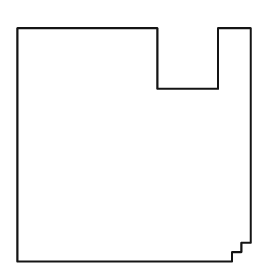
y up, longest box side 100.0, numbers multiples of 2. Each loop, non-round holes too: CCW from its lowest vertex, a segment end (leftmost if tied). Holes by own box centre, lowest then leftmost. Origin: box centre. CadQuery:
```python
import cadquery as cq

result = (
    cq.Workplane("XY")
    .moveTo(-50.0, -50.0)
    .lineTo(42.0, -50.0)
    .lineTo(42.0, -46.0)
    .lineTo(46.0, -46.0)
    .lineTo(46.0, -42.0)
    .lineTo(50.0, -42.0)
    .lineTo(50.0, 50.0)
    .lineTo(36.0, 50.0)
    .lineTo(36.0, 24.0)
    .lineTo(10.0, 24.0)
    .lineTo(10.0, 50.0)
    .lineTo(-50.0, 50.0)
    .close()
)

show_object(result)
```